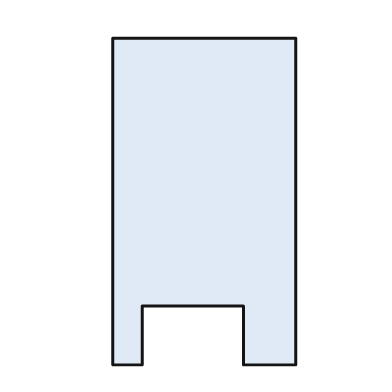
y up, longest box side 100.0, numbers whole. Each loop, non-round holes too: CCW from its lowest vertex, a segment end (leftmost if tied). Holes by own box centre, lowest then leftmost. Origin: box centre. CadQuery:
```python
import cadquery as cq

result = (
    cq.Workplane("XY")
    .moveTo(-28.0, -50.0)
    .lineTo(-19.0, -50.0)
    .lineTo(-19.0, -32.0)
    .lineTo(12.0, -32.0)
    .lineTo(12.0, -50.0)
    .lineTo(28.0, -50.0)
    .lineTo(28.0, 50.0)
    .lineTo(-28.0, 50.0)
    .close()
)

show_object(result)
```